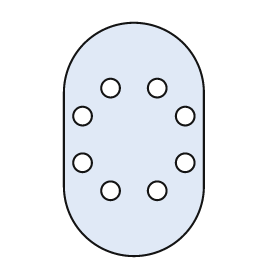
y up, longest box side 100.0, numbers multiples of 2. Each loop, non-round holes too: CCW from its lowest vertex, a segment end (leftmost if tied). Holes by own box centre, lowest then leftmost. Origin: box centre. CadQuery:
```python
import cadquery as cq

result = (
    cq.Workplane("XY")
    .moveTo(-30.0, -20.0)
    .threePointArc((0.0, -50.0), (30.0, -20.0))
    .lineTo(30.0, 20.0)
    .threePointArc((0.0, 50.0), (-30.0, 20.0))
    .close()
    .moveTo(-10.0, -22.0)
    .circle(4.0)
    .moveTo(10.0, -22.0)
    .circle(4.0)
    .moveTo(-22.0, -10.0)
    .circle(4.0)
    .moveTo(22.0, -10.0)
    .circle(4.0)
    .moveTo(-22.0, 10.0)
    .circle(4.0)
    .moveTo(22.0, 10.0)
    .circle(4.0)
    .moveTo(-10.0, 22.0)
    .circle(4.0)
    .moveTo(10.0, 22.0)
    .circle(4.0)
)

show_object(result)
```